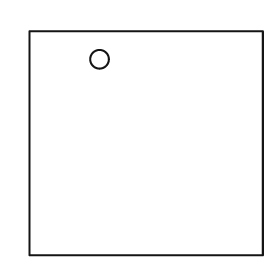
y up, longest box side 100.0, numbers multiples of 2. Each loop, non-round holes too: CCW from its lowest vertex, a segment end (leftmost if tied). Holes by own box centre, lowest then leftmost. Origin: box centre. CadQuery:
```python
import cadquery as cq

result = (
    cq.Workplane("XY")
    .moveTo(-50.0, -48.0)
    .lineTo(50.0, -48.0)
    .lineTo(50.0, 48.0)
    .lineTo(-50.0, 48.0)
    .close()
    .moveTo(-20.0, 36.0)
    .circle(4.0)
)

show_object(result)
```